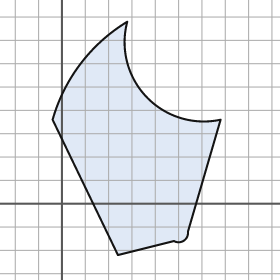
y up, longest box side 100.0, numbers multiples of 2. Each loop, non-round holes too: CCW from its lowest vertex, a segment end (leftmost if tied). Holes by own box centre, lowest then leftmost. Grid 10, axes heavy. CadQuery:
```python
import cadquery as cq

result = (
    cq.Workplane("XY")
    .moveTo(24.0, -22.0)
    .lineTo(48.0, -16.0)
    .threePointArc((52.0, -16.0), (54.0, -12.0))
    .lineTo(68.0, 36.0)
    .threePointArc((36.0, 46.0), (28.0, 78.0))
    .threePointArc((8.0, 60.0), (-4.0, 36.0))
    .close()
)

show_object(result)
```